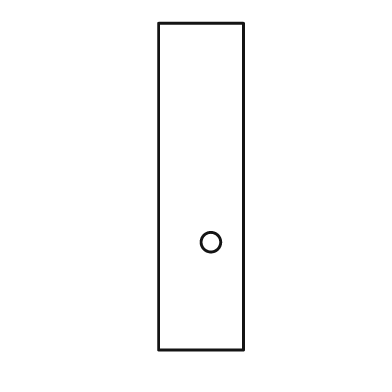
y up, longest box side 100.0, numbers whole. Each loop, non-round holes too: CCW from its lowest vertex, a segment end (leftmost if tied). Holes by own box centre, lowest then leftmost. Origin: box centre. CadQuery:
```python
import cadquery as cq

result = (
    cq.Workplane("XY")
    .moveTo(-13.0, -50.0)
    .lineTo(13.0, -50.0)
    .lineTo(13.0, 50.0)
    .lineTo(-13.0, 50.0)
    .close()
    .moveTo(3.0, -17.0)
    .circle(3.0)
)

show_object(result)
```